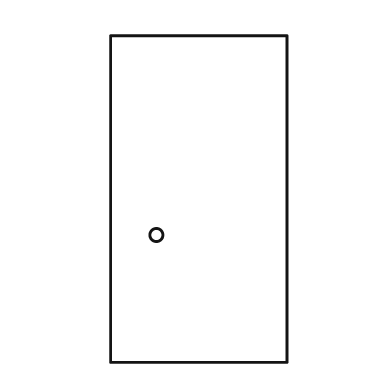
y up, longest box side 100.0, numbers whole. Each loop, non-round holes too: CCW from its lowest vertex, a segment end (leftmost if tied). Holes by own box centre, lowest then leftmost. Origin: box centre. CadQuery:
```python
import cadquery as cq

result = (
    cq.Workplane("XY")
    .moveTo(-27.0, -50.0)
    .lineTo(27.0, -50.0)
    .lineTo(27.0, 50.0)
    .lineTo(-27.0, 50.0)
    .close()
    .moveTo(-13.0, -11.0)
    .circle(2.0)
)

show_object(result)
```